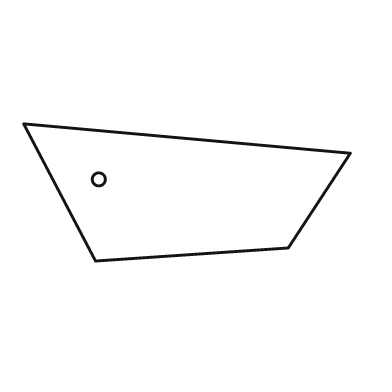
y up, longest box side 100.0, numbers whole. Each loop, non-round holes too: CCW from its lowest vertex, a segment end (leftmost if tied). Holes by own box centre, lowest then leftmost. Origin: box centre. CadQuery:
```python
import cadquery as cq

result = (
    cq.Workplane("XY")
    .moveTo(-28.0, -21.0)
    .lineTo(31.0, -17.0)
    .lineTo(50.0, 12.0)
    .lineTo(-50.0, 21.0)
    .close()
    .moveTo(-27.0, 4.0)
    .circle(2.0)
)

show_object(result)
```